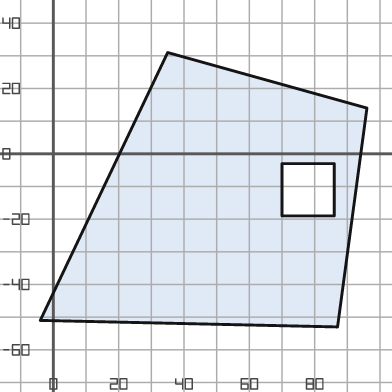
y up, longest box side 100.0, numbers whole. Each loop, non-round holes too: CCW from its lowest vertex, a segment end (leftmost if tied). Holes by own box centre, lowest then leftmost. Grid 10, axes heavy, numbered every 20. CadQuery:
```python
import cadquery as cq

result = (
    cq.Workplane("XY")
    .moveTo(87.0, -53.0)
    .lineTo(96.0, 14.0)
    .lineTo(35.0, 31.0)
    .lineTo(-4.0, -51.0)
    .close()
    .moveTo(70.0, -19.0)
    .lineTo(86.0, -19.0)
    .lineTo(86.0, -3.0)
    .lineTo(70.0, -3.0)
    .close()
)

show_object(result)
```